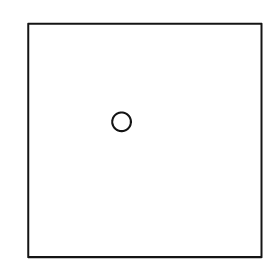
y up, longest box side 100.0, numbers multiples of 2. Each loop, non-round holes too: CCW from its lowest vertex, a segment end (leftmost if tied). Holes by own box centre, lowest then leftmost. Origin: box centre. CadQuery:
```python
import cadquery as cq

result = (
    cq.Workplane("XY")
    .moveTo(-50.0, -50.0)
    .lineTo(50.0, -50.0)
    .lineTo(50.0, 50.0)
    .lineTo(-50.0, 50.0)
    .close()
    .moveTo(-10.0, 8.0)
    .circle(4.0)
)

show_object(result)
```